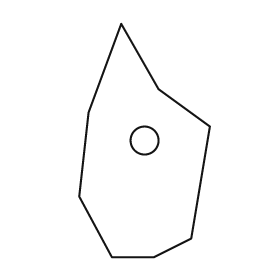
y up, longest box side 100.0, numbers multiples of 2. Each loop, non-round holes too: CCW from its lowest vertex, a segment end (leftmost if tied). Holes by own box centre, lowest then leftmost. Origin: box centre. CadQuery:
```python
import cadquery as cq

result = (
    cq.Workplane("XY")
    .moveTo(-14.0, -50.0)
    .lineTo(4.0, -50.0)
    .lineTo(20.0, -42.0)
    .lineTo(28.0, 6.0)
    .lineTo(6.0, 22.0)
    .lineTo(-10.0, 50.0)
    .lineTo(-24.0, 12.0)
    .lineTo(-28.0, -24.0)
    .close()
    .moveTo(0.0, 0.0)
    .circle(6.0)
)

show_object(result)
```